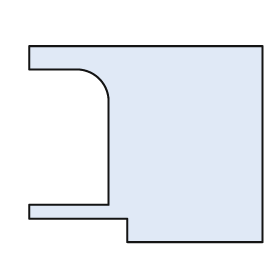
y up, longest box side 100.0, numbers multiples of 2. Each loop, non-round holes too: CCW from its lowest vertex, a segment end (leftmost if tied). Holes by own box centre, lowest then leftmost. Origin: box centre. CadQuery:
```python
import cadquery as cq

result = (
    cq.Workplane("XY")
    .moveTo(-8.0, -42.0)
    .lineTo(50.0, -42.0)
    .lineTo(50.0, 42.0)
    .lineTo(-50.0, 42.0)
    .lineTo(-50.0, 32.0)
    .lineTo(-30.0, 32.0)
    .threePointArc((-20.0, 28.0), (-16.0, 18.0))
    .lineTo(-16.0, -26.0)
    .lineTo(-50.0, -26.0)
    .lineTo(-50.0, -32.0)
    .lineTo(-8.0, -32.0)
    .close()
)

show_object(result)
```